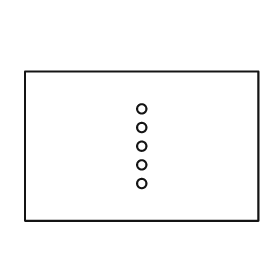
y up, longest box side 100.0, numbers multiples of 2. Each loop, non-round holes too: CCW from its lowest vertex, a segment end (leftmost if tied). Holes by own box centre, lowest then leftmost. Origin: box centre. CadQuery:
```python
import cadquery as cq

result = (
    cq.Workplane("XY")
    .moveTo(-50.0, -32.0)
    .lineTo(50.0, -32.0)
    .lineTo(50.0, 32.0)
    .lineTo(-50.0, 32.0)
    .close()
    .moveTo(0.0, -16.0)
    .circle(2.0)
    .moveTo(0.0, -8.0)
    .circle(2.0)
    .moveTo(0.0, 0.0)
    .circle(2.0)
    .moveTo(0.0, 8.0)
    .circle(2.0)
    .moveTo(0.0, 16.0)
    .circle(2.0)
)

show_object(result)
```